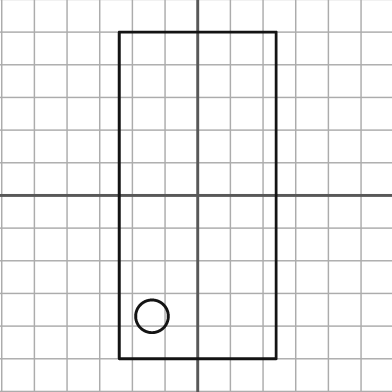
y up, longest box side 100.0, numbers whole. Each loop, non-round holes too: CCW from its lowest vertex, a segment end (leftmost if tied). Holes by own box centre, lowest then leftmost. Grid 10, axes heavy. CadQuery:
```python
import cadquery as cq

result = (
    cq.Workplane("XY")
    .moveTo(-24.0, -50.0)
    .lineTo(24.0, -50.0)
    .lineTo(24.0, 50.0)
    .lineTo(-24.0, 50.0)
    .close()
    .moveTo(-14.0, -37.0)
    .circle(5.0)
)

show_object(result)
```